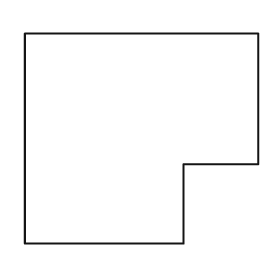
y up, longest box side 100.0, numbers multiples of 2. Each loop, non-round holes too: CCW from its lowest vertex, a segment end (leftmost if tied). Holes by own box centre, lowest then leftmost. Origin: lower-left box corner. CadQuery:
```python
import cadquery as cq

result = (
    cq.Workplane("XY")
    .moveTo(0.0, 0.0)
    .lineTo(68.0, 0.0)
    .lineTo(68.0, 34.0)
    .lineTo(100.0, 34.0)
    .lineTo(100.0, 90.0)
    .lineTo(0.0, 90.0)
    .close()
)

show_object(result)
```